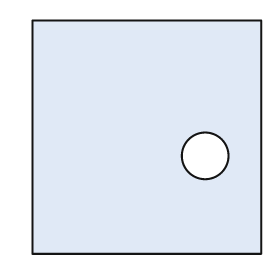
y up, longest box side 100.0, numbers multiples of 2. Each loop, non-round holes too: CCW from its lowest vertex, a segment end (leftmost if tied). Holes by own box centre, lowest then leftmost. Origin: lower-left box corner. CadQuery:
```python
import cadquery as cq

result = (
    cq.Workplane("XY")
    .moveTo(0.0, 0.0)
    .lineTo(98.0, 0.0)
    .lineTo(98.0, 100.0)
    .lineTo(0.0, 100.0)
    .close()
    .moveTo(74.0, 42.0)
    .circle(10.0)
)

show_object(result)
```